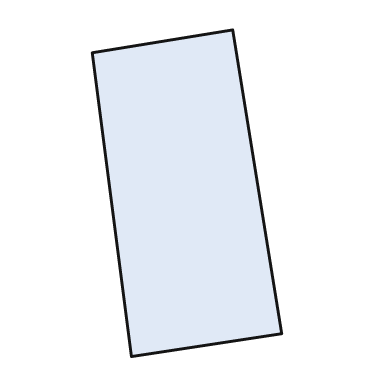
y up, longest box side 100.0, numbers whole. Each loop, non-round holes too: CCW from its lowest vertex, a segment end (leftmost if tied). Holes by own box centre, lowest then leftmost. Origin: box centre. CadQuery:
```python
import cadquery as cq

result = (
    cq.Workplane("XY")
    .moveTo(-17.0, -50.0)
    .lineTo(29.0, -43.0)
    .lineTo(14.0, 50.0)
    .lineTo(-29.0, 43.0)
    .close()
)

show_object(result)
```